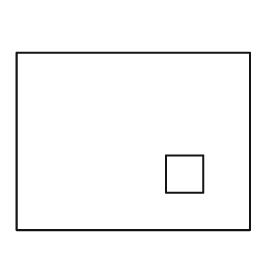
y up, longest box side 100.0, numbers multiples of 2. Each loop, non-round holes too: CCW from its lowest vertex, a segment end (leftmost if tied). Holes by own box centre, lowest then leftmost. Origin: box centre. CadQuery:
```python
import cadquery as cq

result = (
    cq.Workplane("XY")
    .moveTo(-50.0, -38.0)
    .lineTo(50.0, -38.0)
    .lineTo(50.0, 38.0)
    .lineTo(-50.0, 38.0)
    .close()
    .moveTo(14.0, -22.0)
    .lineTo(30.0, -22.0)
    .lineTo(30.0, -6.0)
    .lineTo(14.0, -6.0)
    .close()
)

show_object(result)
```